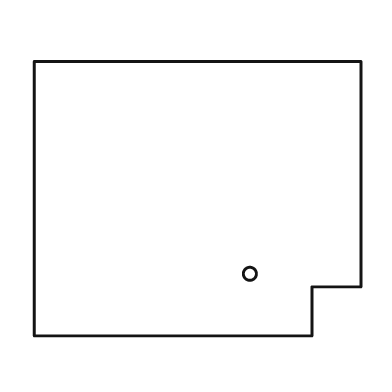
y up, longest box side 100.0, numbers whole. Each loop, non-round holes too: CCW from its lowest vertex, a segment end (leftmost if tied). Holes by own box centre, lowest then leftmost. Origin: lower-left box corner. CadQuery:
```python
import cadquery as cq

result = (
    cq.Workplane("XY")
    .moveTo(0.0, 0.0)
    .lineTo(85.0, 0.0)
    .lineTo(85.0, 15.0)
    .lineTo(100.0, 15.0)
    .lineTo(100.0, 84.0)
    .lineTo(0.0, 84.0)
    .close()
    .moveTo(66.0, 19.0)
    .circle(2.0)
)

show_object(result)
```